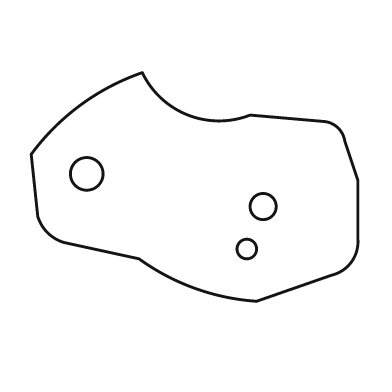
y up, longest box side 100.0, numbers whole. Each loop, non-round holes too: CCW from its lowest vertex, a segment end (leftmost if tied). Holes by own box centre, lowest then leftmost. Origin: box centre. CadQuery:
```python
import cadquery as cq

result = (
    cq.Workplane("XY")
    .moveTo(19.0, -35.0)
    .lineTo(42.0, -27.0)
    .threePointArc((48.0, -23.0), (50.0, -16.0))
    .lineTo(50.0, 2.0)
    .lineTo(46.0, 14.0)
    .threePointArc((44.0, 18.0), (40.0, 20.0))
    .lineTo(17.0, 22.0)
    .threePointArc((-2.0, 22.0), (-16.0, 35.0))
    .threePointArc((-35.0, 25.0), (-50.0, 10.0))
    .lineTo(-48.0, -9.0)
    .threePointArc((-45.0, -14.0), (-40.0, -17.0))
    .lineTo(-17.0, -22.0)
    .threePointArc((0.0, -31.0), (19.0, -35.0))
    .close()
    .moveTo(16.0, -19.0)
    .circle(3.0)
    .moveTo(21.0, -6.0)
    .circle(4.0)
    .moveTo(-33.0, 4.0)
    .circle(5.0)
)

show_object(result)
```